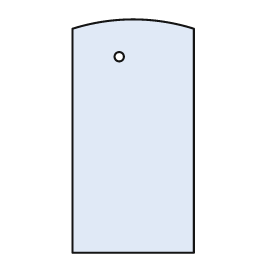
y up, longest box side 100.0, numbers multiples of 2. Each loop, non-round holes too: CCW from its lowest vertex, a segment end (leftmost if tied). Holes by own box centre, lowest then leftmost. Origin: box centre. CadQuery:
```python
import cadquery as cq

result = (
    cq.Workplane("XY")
    .moveTo(-26.0, -50.0)
    .lineTo(26.0, -50.0)
    .lineTo(26.0, 46.0)
    .threePointArc((0.0, 50.0), (-26.0, 46.0))
    .close()
    .moveTo(-6.0, 34.0)
    .circle(2.0)
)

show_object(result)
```